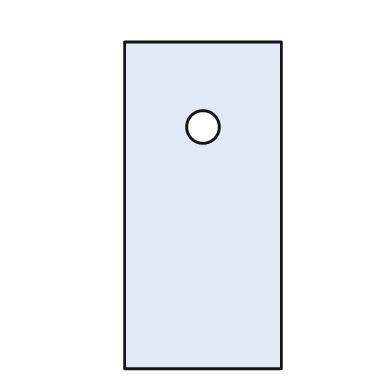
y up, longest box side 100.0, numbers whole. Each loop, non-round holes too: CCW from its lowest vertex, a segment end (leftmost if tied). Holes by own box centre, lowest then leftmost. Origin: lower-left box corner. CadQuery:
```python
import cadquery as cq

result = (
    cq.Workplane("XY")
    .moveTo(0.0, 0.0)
    .lineTo(48.0, 0.0)
    .lineTo(48.0, 100.0)
    .lineTo(0.0, 100.0)
    .close()
    .moveTo(24.0, 74.0)
    .circle(5.0)
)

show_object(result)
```